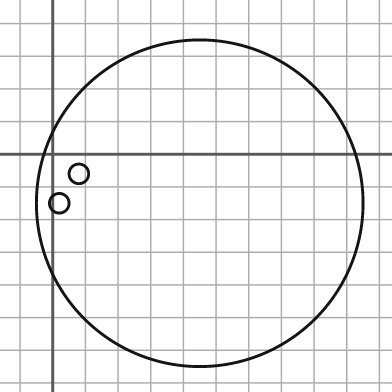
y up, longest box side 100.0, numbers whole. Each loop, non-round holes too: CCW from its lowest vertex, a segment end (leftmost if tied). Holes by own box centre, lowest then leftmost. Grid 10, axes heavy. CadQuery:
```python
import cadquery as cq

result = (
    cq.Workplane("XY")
    .moveTo(45.0, -15.0)
    .circle(50.0)
    .moveTo(2.0, -15.0)
    .circle(3.0)
    .moveTo(8.0, -6.0)
    .circle(3.0)
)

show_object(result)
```